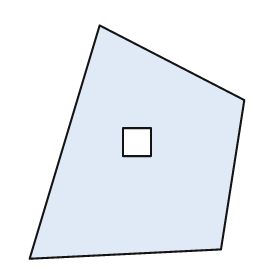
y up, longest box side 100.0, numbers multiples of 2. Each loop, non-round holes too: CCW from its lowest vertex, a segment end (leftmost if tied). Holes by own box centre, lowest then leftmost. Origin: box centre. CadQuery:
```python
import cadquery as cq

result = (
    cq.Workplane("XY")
    .moveTo(-46.0, -50.0)
    .lineTo(36.0, -46.0)
    .lineTo(46.0, 18.0)
    .lineTo(-16.0, 50.0)
    .close()
    .moveTo(-6.0, -6.0)
    .lineTo(6.0, -6.0)
    .lineTo(6.0, 6.0)
    .lineTo(-6.0, 6.0)
    .close()
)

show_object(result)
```